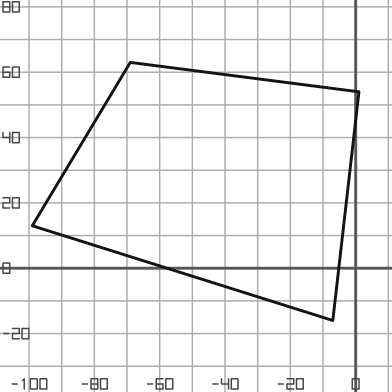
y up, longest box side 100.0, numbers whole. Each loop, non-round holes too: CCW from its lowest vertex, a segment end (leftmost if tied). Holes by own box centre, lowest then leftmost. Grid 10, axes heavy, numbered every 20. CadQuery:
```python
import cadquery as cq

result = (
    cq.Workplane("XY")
    .moveTo(-7.0, -16.0)
    .lineTo(1.0, 54.0)
    .lineTo(-69.0, 63.0)
    .lineTo(-99.0, 13.0)
    .close()
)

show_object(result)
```